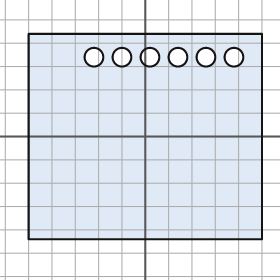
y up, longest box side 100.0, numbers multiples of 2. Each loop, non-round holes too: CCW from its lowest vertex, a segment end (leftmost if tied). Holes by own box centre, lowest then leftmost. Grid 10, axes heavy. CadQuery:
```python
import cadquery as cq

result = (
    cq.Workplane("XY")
    .moveTo(-50.0, -44.0)
    .lineTo(50.0, -44.0)
    .lineTo(50.0, 44.0)
    .lineTo(-50.0, 44.0)
    .close()
    .moveTo(-22.0, 34.0)
    .circle(4.0)
    .moveTo(-10.0, 34.0)
    .circle(4.0)
    .moveTo(2.0, 34.0)
    .circle(4.0)
    .moveTo(14.0, 34.0)
    .circle(4.0)
    .moveTo(26.0, 34.0)
    .circle(4.0)
    .moveTo(38.0, 34.0)
    .circle(4.0)
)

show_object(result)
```